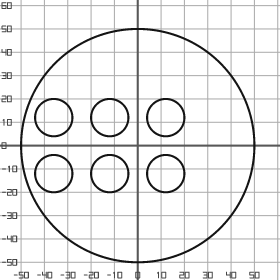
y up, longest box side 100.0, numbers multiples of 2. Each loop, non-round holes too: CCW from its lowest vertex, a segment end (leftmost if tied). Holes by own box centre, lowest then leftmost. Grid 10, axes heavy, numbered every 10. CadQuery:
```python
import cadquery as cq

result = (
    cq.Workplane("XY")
    .moveTo(0.0, 0.0)
    .circle(50.0)
    .moveTo(-36.0, -12.0)
    .circle(8.0)
    .moveTo(-12.0, -12.0)
    .circle(8.0)
    .moveTo(12.0, -12.0)
    .circle(8.0)
    .moveTo(-36.0, 12.0)
    .circle(8.0)
    .moveTo(-12.0, 12.0)
    .circle(8.0)
    .moveTo(12.0, 12.0)
    .circle(8.0)
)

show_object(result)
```